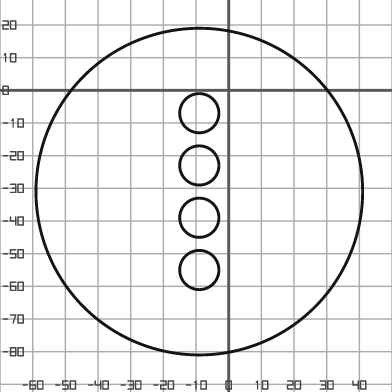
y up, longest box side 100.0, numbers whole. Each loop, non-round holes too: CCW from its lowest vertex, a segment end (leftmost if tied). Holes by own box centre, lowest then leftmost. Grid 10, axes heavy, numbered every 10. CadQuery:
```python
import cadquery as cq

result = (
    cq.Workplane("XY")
    .moveTo(-9.0, -31.0)
    .circle(50.0)
    .moveTo(-9.0, -55.0)
    .circle(6.0)
    .moveTo(-9.0, -39.0)
    .circle(6.0)
    .moveTo(-9.0, -23.0)
    .circle(6.0)
    .moveTo(-9.0, -7.0)
    .circle(6.0)
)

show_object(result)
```